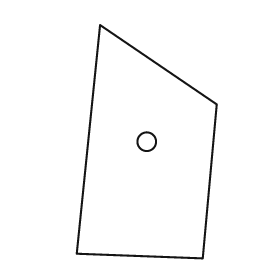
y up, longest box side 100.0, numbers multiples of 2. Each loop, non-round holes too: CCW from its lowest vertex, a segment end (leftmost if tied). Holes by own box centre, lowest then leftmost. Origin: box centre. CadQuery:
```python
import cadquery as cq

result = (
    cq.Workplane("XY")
    .moveTo(24.0, -50.0)
    .lineTo(30.0, 16.0)
    .lineTo(-20.0, 50.0)
    .lineTo(-30.0, -48.0)
    .close()
    .moveTo(0.0, 0.0)
    .circle(4.0)
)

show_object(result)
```